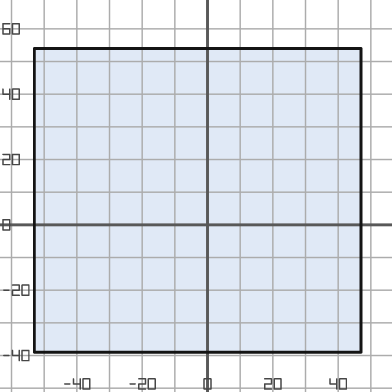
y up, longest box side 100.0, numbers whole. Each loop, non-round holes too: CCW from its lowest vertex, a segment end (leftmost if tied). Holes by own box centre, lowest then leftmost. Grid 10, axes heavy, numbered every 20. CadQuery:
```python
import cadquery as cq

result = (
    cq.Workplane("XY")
    .moveTo(-53.0, -39.0)
    .lineTo(47.0, -39.0)
    .lineTo(47.0, 54.0)
    .lineTo(-53.0, 54.0)
    .close()
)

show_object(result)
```